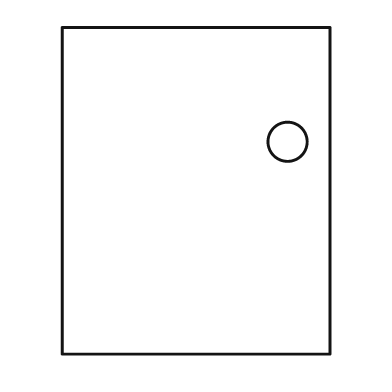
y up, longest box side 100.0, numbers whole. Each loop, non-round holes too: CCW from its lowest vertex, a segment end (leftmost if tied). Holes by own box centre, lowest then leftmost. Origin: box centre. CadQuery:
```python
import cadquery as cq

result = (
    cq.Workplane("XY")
    .moveTo(-41.0, -50.0)
    .lineTo(41.0, -50.0)
    .lineTo(41.0, 50.0)
    .lineTo(-41.0, 50.0)
    .close()
    .moveTo(28.0, 15.0)
    .circle(6.0)
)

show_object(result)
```